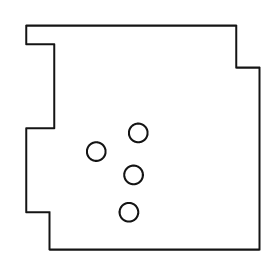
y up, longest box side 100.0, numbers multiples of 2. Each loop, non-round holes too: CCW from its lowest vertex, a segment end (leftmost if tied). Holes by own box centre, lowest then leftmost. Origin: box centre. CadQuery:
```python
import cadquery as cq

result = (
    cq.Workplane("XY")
    .moveTo(-40.0, -48.0)
    .lineTo(50.0, -48.0)
    .lineTo(50.0, 30.0)
    .lineTo(40.0, 30.0)
    .lineTo(40.0, 48.0)
    .lineTo(-50.0, 48.0)
    .lineTo(-50.0, 40.0)
    .lineTo(-38.0, 40.0)
    .lineTo(-38.0, 4.0)
    .lineTo(-50.0, 4.0)
    .lineTo(-50.0, -32.0)
    .lineTo(-40.0, -32.0)
    .close()
    .moveTo(-6.0, -32.0)
    .circle(4.0)
    .moveTo(-4.0, -16.0)
    .circle(4.0)
    .moveTo(-20.0, -6.0)
    .circle(4.0)
    .moveTo(-2.0, 2.0)
    .circle(4.0)
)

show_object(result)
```